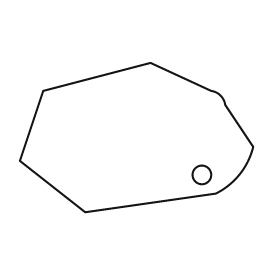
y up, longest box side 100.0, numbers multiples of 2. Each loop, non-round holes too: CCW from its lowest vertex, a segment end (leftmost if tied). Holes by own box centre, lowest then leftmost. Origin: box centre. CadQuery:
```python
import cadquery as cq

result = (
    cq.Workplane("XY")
    .moveTo(-22.0, -32.0)
    .lineTo(34.0, -24.0)
    .threePointArc((44.0, -16.0), (50.0, -4.0))
    .lineTo(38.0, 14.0)
    .threePointArc((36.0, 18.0), (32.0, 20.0))
    .lineTo(6.0, 32.0)
    .lineTo(-40.0, 20.0)
    .lineTo(-50.0, -10.0)
    .close()
    .moveTo(28.0, -16.0)
    .circle(4.0)
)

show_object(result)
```